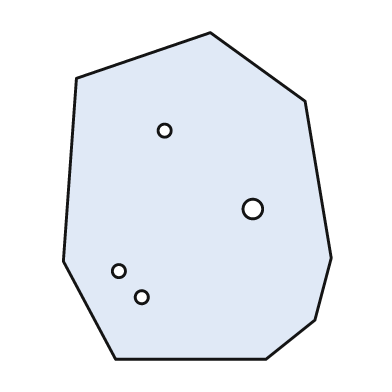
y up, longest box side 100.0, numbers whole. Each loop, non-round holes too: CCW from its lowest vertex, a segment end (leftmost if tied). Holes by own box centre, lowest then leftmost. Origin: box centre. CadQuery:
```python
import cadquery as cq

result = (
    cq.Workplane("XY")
    .moveTo(-25.0, -50.0)
    .lineTo(21.0, -50.0)
    .lineTo(36.0, -38.0)
    .lineTo(41.0, -19.0)
    .lineTo(33.0, 29.0)
    .lineTo(4.0, 50.0)
    .lineTo(-37.0, 36.0)
    .lineTo(-41.0, -20.0)
    .close()
    .moveTo(-17.0, -31.0)
    .circle(2.0)
    .moveTo(-24.0, -23.0)
    .circle(2.0)
    .moveTo(17.0, -4.0)
    .circle(3.0)
    .moveTo(-10.0, 20.0)
    .circle(2.0)
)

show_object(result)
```